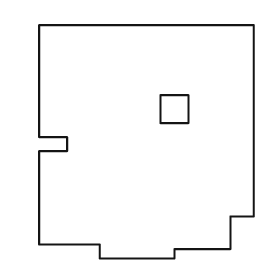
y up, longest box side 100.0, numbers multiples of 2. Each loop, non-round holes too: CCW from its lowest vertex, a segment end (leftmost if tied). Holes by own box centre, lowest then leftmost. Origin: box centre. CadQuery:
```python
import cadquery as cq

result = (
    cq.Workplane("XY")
    .moveTo(-20.0, -50.0)
    .lineTo(12.0, -50.0)
    .lineTo(12.0, -46.0)
    .lineTo(36.0, -46.0)
    .lineTo(36.0, -32.0)
    .lineTo(46.0, -32.0)
    .lineTo(46.0, 50.0)
    .lineTo(-46.0, 50.0)
    .lineTo(-46.0, 2.0)
    .lineTo(-34.0, 2.0)
    .lineTo(-34.0, -4.0)
    .lineTo(-46.0, -4.0)
    .lineTo(-46.0, -44.0)
    .lineTo(-20.0, -44.0)
    .close()
    .moveTo(6.0, 8.0)
    .lineTo(18.0, 8.0)
    .lineTo(18.0, 20.0)
    .lineTo(6.0, 20.0)
    .close()
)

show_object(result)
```